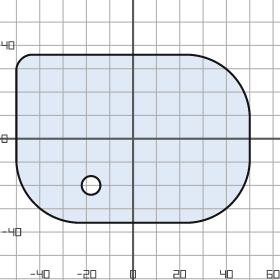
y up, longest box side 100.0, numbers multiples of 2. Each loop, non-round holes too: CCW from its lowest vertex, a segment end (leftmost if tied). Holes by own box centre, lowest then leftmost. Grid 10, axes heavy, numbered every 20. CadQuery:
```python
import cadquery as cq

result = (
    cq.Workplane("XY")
    .moveTo(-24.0, -36.0)
    .lineTo(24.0, -36.0)
    .threePointArc((42.0, -28.0), (50.0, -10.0))
    .lineTo(50.0, 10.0)
    .threePointArc((42.0, 28.0), (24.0, 36.0))
    .lineTo(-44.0, 36.0)
    .threePointArc((-48.0, 34.0), (-50.0, 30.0))
    .lineTo(-50.0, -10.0)
    .threePointArc((-42.0, -28.0), (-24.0, -36.0))
    .close()
    .moveTo(-18.0, -20.0)
    .circle(4.0)
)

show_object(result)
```